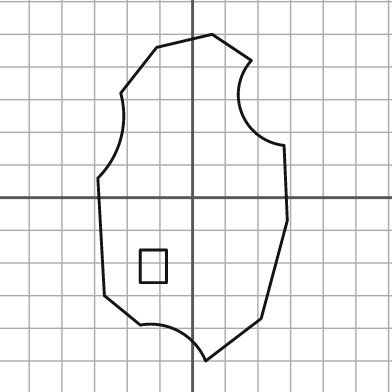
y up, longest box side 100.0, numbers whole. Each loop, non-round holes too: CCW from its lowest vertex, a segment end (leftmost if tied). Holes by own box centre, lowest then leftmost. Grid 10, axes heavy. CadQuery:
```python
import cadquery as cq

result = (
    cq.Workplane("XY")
    .moveTo(4.0, -50.0)
    .lineTo(21.0, -37.0)
    .lineTo(29.0, -7.0)
    .lineTo(28.0, 16.0)
    .threePointArc((15.0, 26.0), (18.0, 42.0))
    .lineTo(6.0, 50.0)
    .lineTo(-11.0, 46.0)
    .lineTo(-22.0, 32.0)
    .threePointArc((-22.0, 18.0), (-29.0, 6.0))
    .lineTo(-27.0, -30.0)
    .lineTo(-16.0, -39.0)
    .threePointArc((-4.0, -41.0), (4.0, -50.0))
    .close()
    .moveTo(-16.0, -26.0)
    .lineTo(-8.0, -26.0)
    .lineTo(-8.0, -16.0)
    .lineTo(-16.0, -16.0)
    .close()
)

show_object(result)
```